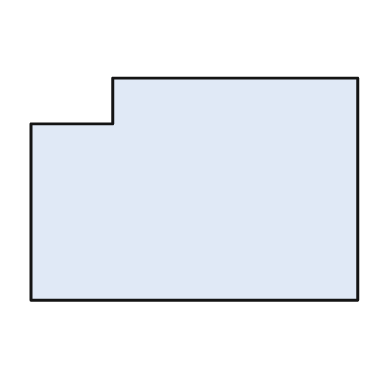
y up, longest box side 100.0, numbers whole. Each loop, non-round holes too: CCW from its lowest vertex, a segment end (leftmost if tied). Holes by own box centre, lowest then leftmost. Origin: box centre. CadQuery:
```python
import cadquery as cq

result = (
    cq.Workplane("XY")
    .moveTo(-50.0, -34.0)
    .lineTo(50.0, -34.0)
    .lineTo(50.0, 34.0)
    .lineTo(-25.0, 34.0)
    .lineTo(-25.0, 20.0)
    .lineTo(-50.0, 20.0)
    .close()
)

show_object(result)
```